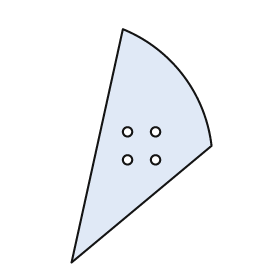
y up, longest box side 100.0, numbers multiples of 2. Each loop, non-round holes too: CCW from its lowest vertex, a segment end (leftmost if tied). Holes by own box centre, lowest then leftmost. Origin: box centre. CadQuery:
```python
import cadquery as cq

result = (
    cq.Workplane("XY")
    .moveTo(-30.0, -50.0)
    .lineTo(30.0, 0.0)
    .threePointArc((18.0, 30.0), (-8.0, 50.0))
    .close()
    .moveTo(-6.0, -6.0)
    .circle(2.0)
    .moveTo(6.0, -6.0)
    .circle(2.0)
    .moveTo(-6.0, 6.0)
    .circle(2.0)
    .moveTo(6.0, 6.0)
    .circle(2.0)
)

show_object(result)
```